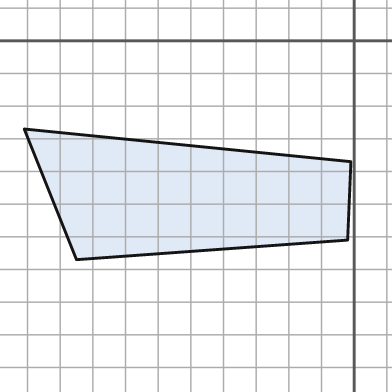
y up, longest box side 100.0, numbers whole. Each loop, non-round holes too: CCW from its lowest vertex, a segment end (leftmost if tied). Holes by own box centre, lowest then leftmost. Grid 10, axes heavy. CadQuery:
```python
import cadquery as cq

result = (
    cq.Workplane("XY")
    .moveTo(-85.0, -67.0)
    .lineTo(-2.0, -61.0)
    .lineTo(-1.0, -37.0)
    .lineTo(-101.0, -27.0)
    .close()
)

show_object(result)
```